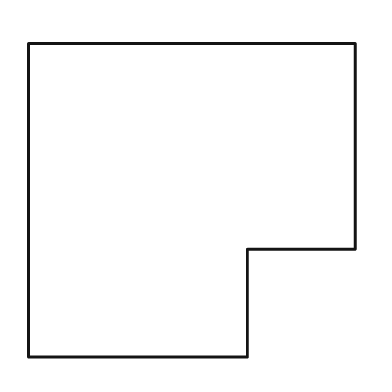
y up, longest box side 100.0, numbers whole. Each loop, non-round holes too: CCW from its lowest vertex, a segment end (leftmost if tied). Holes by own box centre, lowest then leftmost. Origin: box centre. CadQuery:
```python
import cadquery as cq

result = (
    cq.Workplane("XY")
    .moveTo(-50.0, -48.0)
    .lineTo(17.0, -48.0)
    .lineTo(17.0, -15.0)
    .lineTo(50.0, -15.0)
    .lineTo(50.0, 48.0)
    .lineTo(-50.0, 48.0)
    .close()
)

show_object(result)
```